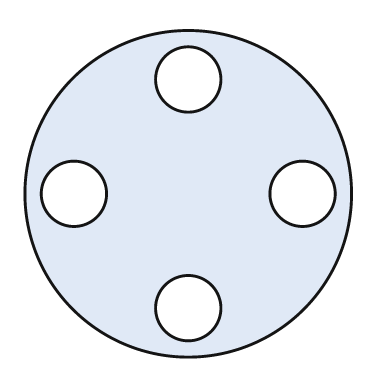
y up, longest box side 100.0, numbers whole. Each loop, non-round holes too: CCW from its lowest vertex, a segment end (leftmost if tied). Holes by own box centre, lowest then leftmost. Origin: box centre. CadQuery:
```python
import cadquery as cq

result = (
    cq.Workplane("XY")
    .moveTo(0.0, 0.0)
    .circle(50.0)
    .moveTo(0.0, -35.0)
    .circle(10.0)
    .moveTo(-35.0, 0.0)
    .circle(10.0)
    .moveTo(35.0, 0.0)
    .circle(10.0)
    .moveTo(0.0, 35.0)
    .circle(10.0)
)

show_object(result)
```